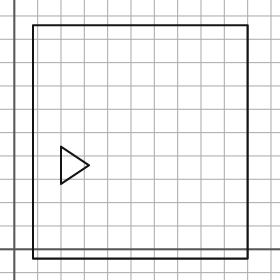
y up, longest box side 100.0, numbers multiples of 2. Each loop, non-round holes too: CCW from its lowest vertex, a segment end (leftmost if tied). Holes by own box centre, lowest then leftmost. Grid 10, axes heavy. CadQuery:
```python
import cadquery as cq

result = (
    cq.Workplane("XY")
    .moveTo(8.0, -4.0)
    .lineTo(100.0, -4.0)
    .lineTo(100.0, 96.0)
    .lineTo(8.0, 96.0)
    .close()
    .moveTo(20.0, 28.0)
    .lineTo(32.0, 36.0)
    .lineTo(20.0, 44.0)
    .close()
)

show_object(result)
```